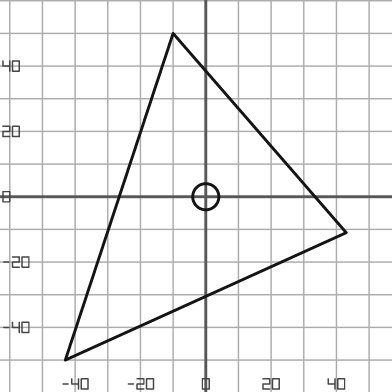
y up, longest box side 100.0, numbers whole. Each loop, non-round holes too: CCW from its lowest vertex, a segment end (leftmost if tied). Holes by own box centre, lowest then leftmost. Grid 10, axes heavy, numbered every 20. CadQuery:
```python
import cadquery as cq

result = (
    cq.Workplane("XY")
    .moveTo(-43.0, -50.0)
    .lineTo(43.0, -11.0)
    .lineTo(-10.0, 50.0)
    .close()
    .moveTo(0.0, 0.0)
    .circle(4.0)
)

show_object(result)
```